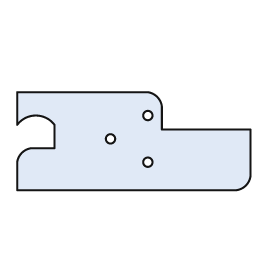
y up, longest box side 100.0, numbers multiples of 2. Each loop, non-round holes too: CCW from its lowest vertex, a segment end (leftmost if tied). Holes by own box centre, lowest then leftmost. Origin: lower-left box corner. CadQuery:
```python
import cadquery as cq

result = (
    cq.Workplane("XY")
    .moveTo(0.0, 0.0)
    .lineTo(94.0, 0.0)
    .threePointArc((98.0, 2.0), (100.0, 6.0))
    .lineTo(100.0, 26.0)
    .lineTo(62.0, 26.0)
    .lineTo(62.0, 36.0)
    .threePointArc((60.0, 40.0), (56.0, 42.0))
    .lineTo(0.0, 42.0)
    .lineTo(0.0, 28.0)
    .threePointArc((8.0, 32.0), (16.0, 28.0))
    .lineTo(16.0, 18.0)
    .lineTo(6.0, 18.0)
    .threePointArc((2.0, 16.0), (0.0, 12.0))
    .close()
    .moveTo(56.0, 12.0)
    .circle(2.0)
    .moveTo(40.0, 22.0)
    .circle(2.0)
    .moveTo(56.0, 32.0)
    .circle(2.0)
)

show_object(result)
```